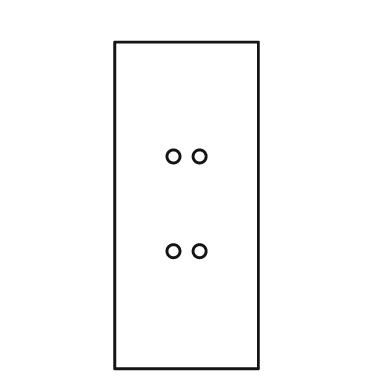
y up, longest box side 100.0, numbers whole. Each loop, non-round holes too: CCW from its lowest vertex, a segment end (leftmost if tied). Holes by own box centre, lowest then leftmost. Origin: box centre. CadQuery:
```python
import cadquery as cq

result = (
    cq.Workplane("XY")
    .moveTo(-22.0, -50.0)
    .lineTo(22.0, -50.0)
    .lineTo(22.0, 50.0)
    .lineTo(-22.0, 50.0)
    .close()
    .moveTo(-4.0, -14.0)
    .circle(2.0)
    .moveTo(4.0, -14.0)
    .circle(2.0)
    .moveTo(-4.0, 15.0)
    .circle(2.0)
    .moveTo(4.0, 15.0)
    .circle(2.0)
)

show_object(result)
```